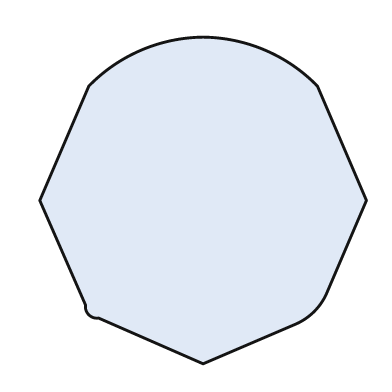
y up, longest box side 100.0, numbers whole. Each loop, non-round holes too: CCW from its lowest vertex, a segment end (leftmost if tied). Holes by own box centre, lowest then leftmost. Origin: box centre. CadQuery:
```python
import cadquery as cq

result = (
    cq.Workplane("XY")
    .moveTo(0.0, -50.0)
    .lineTo(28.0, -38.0)
    .threePointArc((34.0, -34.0), (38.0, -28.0))
    .lineTo(50.0, 0.0)
    .lineTo(35.0, 35.0)
    .threePointArc((19.0, 46.0), (0.0, 50.0))
    .threePointArc((-19.0, 46.0), (-35.0, 35.0))
    .lineTo(-50.0, 0.0)
    .lineTo(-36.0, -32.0)
    .threePointArc((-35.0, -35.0), (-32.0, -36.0))
    .close()
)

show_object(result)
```